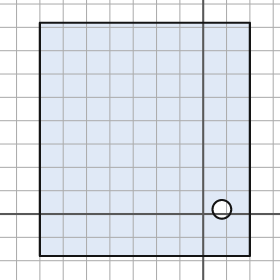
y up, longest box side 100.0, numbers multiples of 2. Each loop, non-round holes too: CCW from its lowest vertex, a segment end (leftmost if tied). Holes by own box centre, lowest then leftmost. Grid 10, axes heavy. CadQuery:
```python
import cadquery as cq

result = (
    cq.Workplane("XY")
    .moveTo(-70.0, -18.0)
    .lineTo(20.0, -18.0)
    .lineTo(20.0, 82.0)
    .lineTo(-70.0, 82.0)
    .close()
    .moveTo(8.0, 2.0)
    .circle(4.0)
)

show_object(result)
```